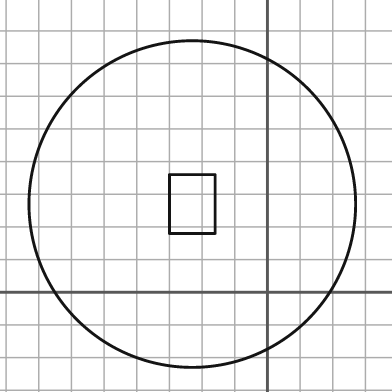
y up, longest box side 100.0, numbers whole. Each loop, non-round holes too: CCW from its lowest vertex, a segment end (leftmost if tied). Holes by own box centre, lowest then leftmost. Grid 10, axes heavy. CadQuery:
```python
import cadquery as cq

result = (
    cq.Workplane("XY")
    .moveTo(-23.0, 27.0)
    .circle(50.0)
    .moveTo(-30.0, 18.0)
    .lineTo(-16.0, 18.0)
    .lineTo(-16.0, 36.0)
    .lineTo(-30.0, 36.0)
    .close()
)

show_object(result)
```